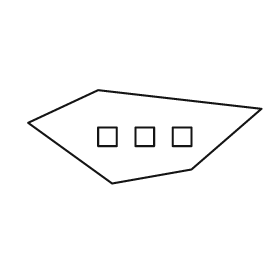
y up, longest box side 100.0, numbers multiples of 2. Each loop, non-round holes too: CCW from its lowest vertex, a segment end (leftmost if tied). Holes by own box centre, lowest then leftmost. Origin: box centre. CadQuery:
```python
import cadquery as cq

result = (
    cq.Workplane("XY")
    .moveTo(-14.0, -20.0)
    .lineTo(20.0, -14.0)
    .lineTo(50.0, 12.0)
    .lineTo(-20.0, 20.0)
    .lineTo(-50.0, 6.0)
    .close()
    .moveTo(-20.0, -4.0)
    .lineTo(-12.0, -4.0)
    .lineTo(-12.0, 4.0)
    .lineTo(-20.0, 4.0)
    .close()
    .moveTo(-4.0, -4.0)
    .lineTo(4.0, -4.0)
    .lineTo(4.0, 4.0)
    .lineTo(-4.0, 4.0)
    .close()
    .moveTo(12.0, -4.0)
    .lineTo(20.0, -4.0)
    .lineTo(20.0, 4.0)
    .lineTo(12.0, 4.0)
    .close()
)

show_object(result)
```